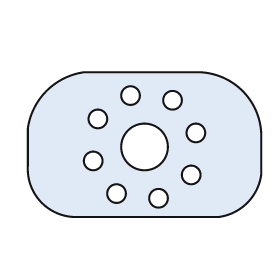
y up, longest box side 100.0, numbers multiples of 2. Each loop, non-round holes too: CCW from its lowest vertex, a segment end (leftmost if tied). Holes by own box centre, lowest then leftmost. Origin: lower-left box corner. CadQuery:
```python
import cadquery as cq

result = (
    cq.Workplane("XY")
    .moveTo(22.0, 0.0)
    .lineTo(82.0, 0.0)
    .threePointArc((94.0, 6.0), (100.0, 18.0))
    .lineTo(100.0, 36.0)
    .threePointArc((92.0, 54.0), (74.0, 62.0))
    .lineTo(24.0, 62.0)
    .threePointArc((8.0, 54.0), (0.0, 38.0))
    .lineTo(0.0, 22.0)
    .threePointArc((6.0, 6.0), (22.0, 0.0))
    .close()
    .moveTo(56.0, 8.0)
    .circle(4.0)
    .moveTo(38.0, 10.0)
    .circle(4.0)
    .moveTo(70.0, 18.0)
    .circle(4.0)
    .moveTo(28.0, 24.0)
    .circle(4.0)
    .moveTo(50.0, 30.0)
    .circle(10.0)
    .moveTo(72.0, 36.0)
    .circle(4.0)
    .moveTo(30.0, 42.0)
    .circle(4.0)
    .moveTo(62.0, 50.0)
    .circle(4.0)
    .moveTo(44.0, 52.0)
    .circle(4.0)
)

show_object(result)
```